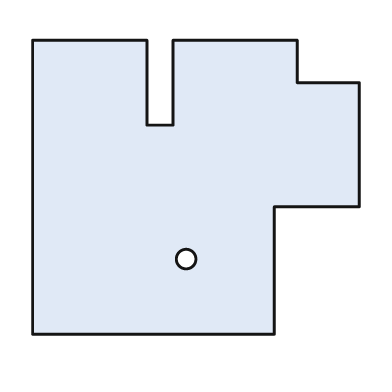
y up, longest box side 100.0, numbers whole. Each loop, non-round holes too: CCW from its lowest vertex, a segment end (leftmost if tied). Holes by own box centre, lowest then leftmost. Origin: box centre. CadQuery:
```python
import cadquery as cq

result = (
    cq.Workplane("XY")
    .moveTo(-50.0, -45.0)
    .lineTo(24.0, -45.0)
    .lineTo(24.0, -6.0)
    .lineTo(50.0, -6.0)
    .lineTo(50.0, 32.0)
    .lineTo(31.0, 32.0)
    .lineTo(31.0, 45.0)
    .lineTo(-7.0, 45.0)
    .lineTo(-7.0, 19.0)
    .lineTo(-15.0, 19.0)
    .lineTo(-15.0, 45.0)
    .lineTo(-50.0, 45.0)
    .close()
    .moveTo(-3.0, -22.0)
    .circle(3.0)
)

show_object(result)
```